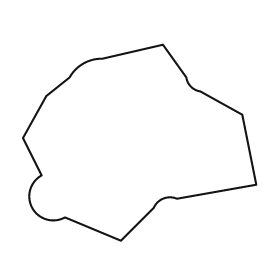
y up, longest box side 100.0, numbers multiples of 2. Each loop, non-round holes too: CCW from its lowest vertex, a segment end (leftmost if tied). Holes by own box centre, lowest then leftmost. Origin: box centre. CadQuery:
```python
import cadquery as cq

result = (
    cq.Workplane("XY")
    .moveTo(-8.0, -42.0)
    .lineTo(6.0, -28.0)
    .threePointArc((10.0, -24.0), (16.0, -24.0))
    .lineTo(50.0, -18.0)
    .lineTo(44.0, 12.0)
    .lineTo(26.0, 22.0)
    .threePointArc((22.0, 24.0), (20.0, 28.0))
    .lineTo(10.0, 42.0)
    .lineTo(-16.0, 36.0)
    .threePointArc((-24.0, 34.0), (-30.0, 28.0))
    .lineTo(-40.0, 20.0)
    .lineTo(-50.0, 2.0)
    .lineTo(-42.0, -14.0)
    .threePointArc((-46.0, -28.0), (-32.0, -32.0))
    .close()
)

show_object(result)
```